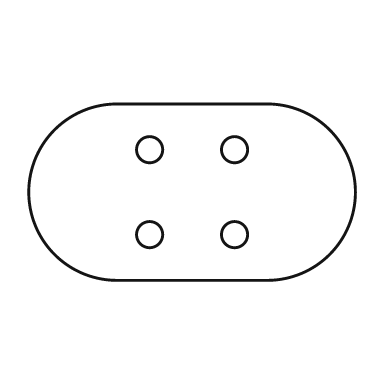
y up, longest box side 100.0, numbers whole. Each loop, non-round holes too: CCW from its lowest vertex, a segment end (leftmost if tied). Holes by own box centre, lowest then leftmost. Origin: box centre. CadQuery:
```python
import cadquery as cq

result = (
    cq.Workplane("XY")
    .moveTo(-23.0, -27.0)
    .lineTo(23.0, -27.0)
    .threePointArc((50.0, 0.0), (23.0, 27.0))
    .lineTo(-23.0, 27.0)
    .threePointArc((-50.0, 0.0), (-23.0, -27.0))
    .close()
    .moveTo(-13.0, -13.0)
    .circle(4.0)
    .moveTo(13.0, -13.0)
    .circle(4.0)
    .moveTo(-13.0, 13.0)
    .circle(4.0)
    .moveTo(13.0, 13.0)
    .circle(4.0)
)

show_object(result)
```